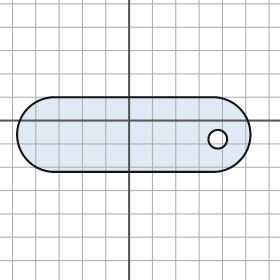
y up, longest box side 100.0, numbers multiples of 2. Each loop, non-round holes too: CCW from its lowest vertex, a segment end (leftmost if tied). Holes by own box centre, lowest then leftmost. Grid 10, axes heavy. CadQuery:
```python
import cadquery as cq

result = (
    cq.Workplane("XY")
    .moveTo(-32.0, -22.0)
    .lineTo(36.0, -22.0)
    .threePointArc((52.0, -6.0), (36.0, 10.0))
    .lineTo(-32.0, 10.0)
    .threePointArc((-48.0, -6.0), (-32.0, -22.0))
    .close()
    .moveTo(38.0, -8.0)
    .circle(4.0)
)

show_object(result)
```